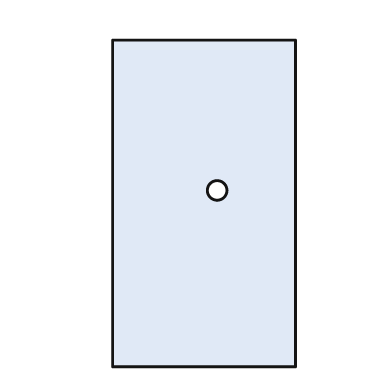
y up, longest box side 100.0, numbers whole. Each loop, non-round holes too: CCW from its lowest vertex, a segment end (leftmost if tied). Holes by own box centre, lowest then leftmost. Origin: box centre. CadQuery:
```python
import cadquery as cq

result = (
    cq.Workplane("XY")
    .moveTo(-28.0, -50.0)
    .lineTo(28.0, -50.0)
    .lineTo(28.0, 50.0)
    .lineTo(-28.0, 50.0)
    .close()
    .moveTo(4.0, 4.0)
    .circle(3.0)
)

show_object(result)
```